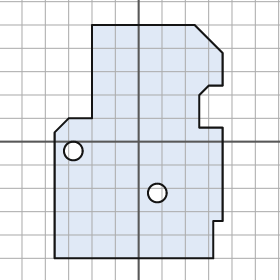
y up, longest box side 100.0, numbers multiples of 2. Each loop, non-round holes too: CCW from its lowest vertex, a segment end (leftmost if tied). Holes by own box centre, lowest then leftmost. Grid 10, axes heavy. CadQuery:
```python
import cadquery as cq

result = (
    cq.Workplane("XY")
    .moveTo(-36.0, -50.0)
    .lineTo(32.0, -50.0)
    .lineTo(32.0, -34.0)
    .lineTo(36.0, -34.0)
    .lineTo(36.0, 6.0)
    .lineTo(26.0, 6.0)
    .lineTo(26.0, 20.0)
    .lineTo(30.0, 24.0)
    .lineTo(36.0, 24.0)
    .lineTo(36.0, 38.0)
    .lineTo(24.0, 50.0)
    .lineTo(-20.0, 50.0)
    .lineTo(-20.0, 10.0)
    .lineTo(-30.0, 10.0)
    .lineTo(-36.0, 4.0)
    .close()
    .moveTo(8.0, -22.0)
    .circle(4.0)
    .moveTo(-28.0, -4.0)
    .circle(4.0)
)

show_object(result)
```